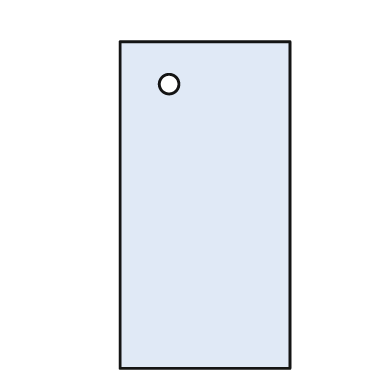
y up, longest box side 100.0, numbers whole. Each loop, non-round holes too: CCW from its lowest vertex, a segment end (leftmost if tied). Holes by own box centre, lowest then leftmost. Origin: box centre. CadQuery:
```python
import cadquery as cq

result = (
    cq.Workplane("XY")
    .moveTo(-26.0, -50.0)
    .lineTo(26.0, -50.0)
    .lineTo(26.0, 50.0)
    .lineTo(-26.0, 50.0)
    .close()
    .moveTo(-11.0, 37.0)
    .circle(3.0)
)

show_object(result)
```